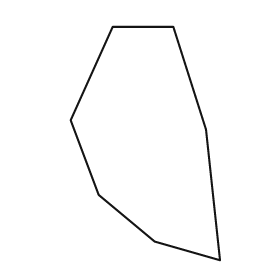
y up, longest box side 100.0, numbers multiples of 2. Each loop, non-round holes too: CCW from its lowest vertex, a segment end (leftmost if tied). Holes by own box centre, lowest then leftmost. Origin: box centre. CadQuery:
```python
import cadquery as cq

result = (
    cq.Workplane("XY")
    .moveTo(32.0, -50.0)
    .lineTo(26.0, 6.0)
    .lineTo(12.0, 50.0)
    .lineTo(-14.0, 50.0)
    .lineTo(-32.0, 10.0)
    .lineTo(-20.0, -22.0)
    .lineTo(4.0, -42.0)
    .close()
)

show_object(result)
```